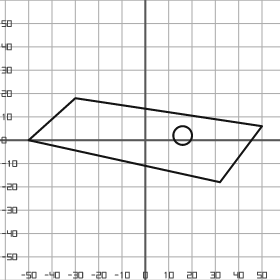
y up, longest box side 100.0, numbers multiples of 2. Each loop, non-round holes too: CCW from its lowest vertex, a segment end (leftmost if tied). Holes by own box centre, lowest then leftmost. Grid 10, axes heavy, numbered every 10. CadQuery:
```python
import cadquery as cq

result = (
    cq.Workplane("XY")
    .moveTo(32.0, -18.0)
    .lineTo(50.0, 6.0)
    .lineTo(-30.0, 18.0)
    .lineTo(-50.0, 0.0)
    .close()
    .moveTo(16.0, 2.0)
    .circle(4.0)
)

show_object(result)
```